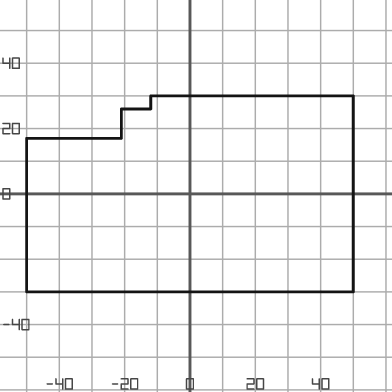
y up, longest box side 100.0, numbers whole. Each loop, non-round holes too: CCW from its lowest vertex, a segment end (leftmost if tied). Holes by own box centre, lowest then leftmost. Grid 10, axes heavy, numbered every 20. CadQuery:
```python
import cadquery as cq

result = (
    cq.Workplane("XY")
    .moveTo(-50.0, -30.0)
    .lineTo(50.0, -30.0)
    .lineTo(50.0, 30.0)
    .lineTo(-12.0, 30.0)
    .lineTo(-12.0, 26.0)
    .lineTo(-21.0, 26.0)
    .lineTo(-21.0, 17.0)
    .lineTo(-50.0, 17.0)
    .close()
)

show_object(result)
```